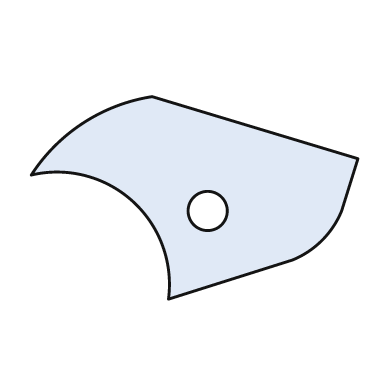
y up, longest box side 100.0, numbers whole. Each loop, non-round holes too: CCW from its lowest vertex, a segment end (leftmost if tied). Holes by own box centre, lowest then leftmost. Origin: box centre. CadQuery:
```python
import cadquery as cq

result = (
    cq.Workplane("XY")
    .moveTo(-8.0, -31.0)
    .lineTo(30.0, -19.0)
    .threePointArc((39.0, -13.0), (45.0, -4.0))
    .lineTo(50.0, 12.0)
    .lineTo(-13.0, 31.0)
    .threePointArc((-34.0, 23.0), (-50.0, 7.0))
    .threePointArc((-19.0, -1.0), (-8.0, -31.0))
    .close()
    .moveTo(4.0, -4.0)
    .circle(6.0)
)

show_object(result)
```